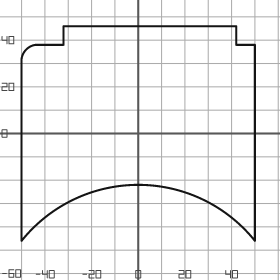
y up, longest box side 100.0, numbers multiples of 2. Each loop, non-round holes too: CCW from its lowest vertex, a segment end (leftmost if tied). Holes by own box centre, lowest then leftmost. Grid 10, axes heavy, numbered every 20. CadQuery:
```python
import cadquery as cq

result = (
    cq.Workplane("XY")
    .moveTo(-50.0, -46.0)
    .threePointArc((0.0, -22.0), (50.0, -46.0))
    .lineTo(50.0, 38.0)
    .lineTo(42.0, 38.0)
    .lineTo(42.0, 46.0)
    .lineTo(-32.0, 46.0)
    .lineTo(-32.0, 38.0)
    .lineTo(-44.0, 38.0)
    .threePointArc((-48.0, 36.0), (-50.0, 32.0))
    .close()
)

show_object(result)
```